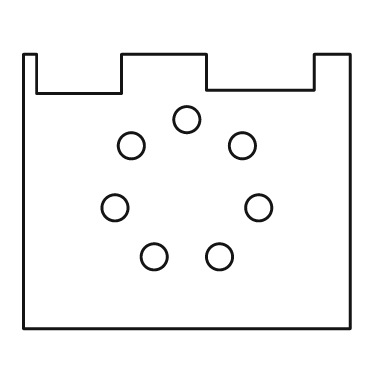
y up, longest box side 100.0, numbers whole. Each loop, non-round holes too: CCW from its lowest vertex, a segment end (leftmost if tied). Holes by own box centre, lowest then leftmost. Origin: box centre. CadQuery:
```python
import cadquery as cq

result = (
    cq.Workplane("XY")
    .moveTo(-50.0, -42.0)
    .lineTo(50.0, -42.0)
    .lineTo(50.0, 42.0)
    .lineTo(39.0, 42.0)
    .lineTo(39.0, 31.0)
    .lineTo(6.0, 31.0)
    .lineTo(6.0, 42.0)
    .lineTo(-20.0, 42.0)
    .lineTo(-20.0, 30.0)
    .lineTo(-46.0, 30.0)
    .lineTo(-46.0, 42.0)
    .lineTo(-50.0, 42.0)
    .close()
    .moveTo(-10.0, -20.0)
    .circle(4.0)
    .moveTo(10.0, -20.0)
    .circle(4.0)
    .moveTo(-22.0, -5.0)
    .circle(4.0)
    .moveTo(22.0, -5.0)
    .circle(4.0)
    .moveTo(-17.0, 14.0)
    .circle(4.0)
    .moveTo(17.0, 14.0)
    .circle(4.0)
    .moveTo(0.0, 22.0)
    .circle(4.0)
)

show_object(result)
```